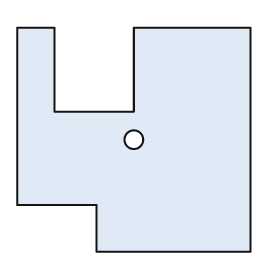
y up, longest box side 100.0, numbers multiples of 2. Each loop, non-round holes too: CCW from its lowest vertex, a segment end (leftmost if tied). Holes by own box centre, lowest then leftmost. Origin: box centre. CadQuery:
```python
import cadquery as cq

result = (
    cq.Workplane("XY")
    .moveTo(-16.0, -48.0)
    .lineTo(50.0, -48.0)
    .lineTo(50.0, 48.0)
    .lineTo(0.0, 48.0)
    .lineTo(0.0, 12.0)
    .lineTo(-34.0, 12.0)
    .lineTo(-34.0, 48.0)
    .lineTo(-50.0, 48.0)
    .lineTo(-50.0, -28.0)
    .lineTo(-16.0, -28.0)
    .close()
    .moveTo(0.0, 0.0)
    .circle(4.0)
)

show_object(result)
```